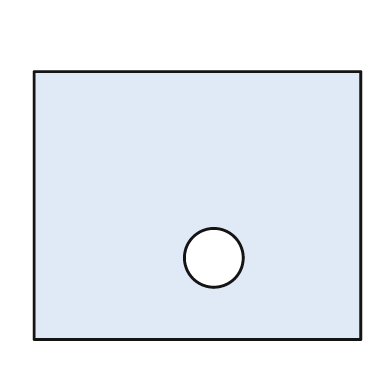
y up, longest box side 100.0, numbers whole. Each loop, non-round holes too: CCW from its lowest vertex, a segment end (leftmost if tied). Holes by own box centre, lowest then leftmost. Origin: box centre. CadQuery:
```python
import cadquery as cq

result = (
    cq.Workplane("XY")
    .moveTo(-50.0, -41.0)
    .lineTo(50.0, -41.0)
    .lineTo(50.0, 41.0)
    .lineTo(-50.0, 41.0)
    .close()
    .moveTo(5.0, -16.0)
    .circle(9.0)
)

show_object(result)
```